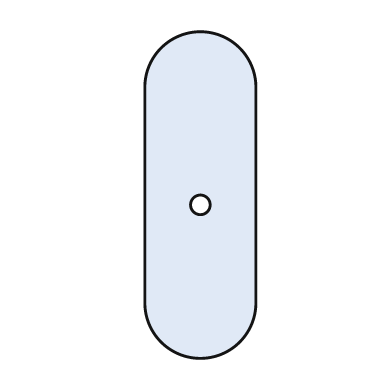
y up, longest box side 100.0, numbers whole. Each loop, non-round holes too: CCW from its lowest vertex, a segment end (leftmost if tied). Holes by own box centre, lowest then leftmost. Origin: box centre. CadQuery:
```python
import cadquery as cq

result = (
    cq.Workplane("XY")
    .moveTo(-17.0, -33.0)
    .threePointArc((0.0, -50.0), (17.0, -33.0))
    .lineTo(17.0, 33.0)
    .threePointArc((0.0, 50.0), (-17.0, 33.0))
    .close()
    .moveTo(0.0, -3.0)
    .circle(3.0)
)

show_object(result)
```